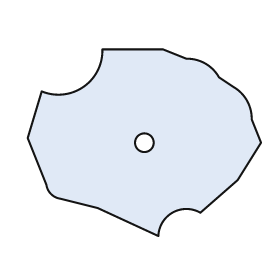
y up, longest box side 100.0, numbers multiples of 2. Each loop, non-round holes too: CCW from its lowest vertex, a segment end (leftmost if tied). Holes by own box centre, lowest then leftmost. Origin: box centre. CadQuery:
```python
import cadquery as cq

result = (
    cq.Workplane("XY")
    .moveTo(6.0, -40.0)
    .threePointArc((12.0, -30.0), (24.0, -30.0))
    .lineTo(40.0, -16.0)
    .lineTo(50.0, 0.0)
    .lineTo(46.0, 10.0)
    .threePointArc((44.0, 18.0), (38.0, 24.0))
    .lineTo(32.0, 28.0)
    .threePointArc((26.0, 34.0), (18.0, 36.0))
    .lineTo(8.0, 40.0)
    .lineTo(-18.0, 40.0)
    .threePointArc((-26.0, 24.0), (-44.0, 22.0))
    .lineTo(-50.0, 2.0)
    .lineTo(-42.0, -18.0)
    .threePointArc((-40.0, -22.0), (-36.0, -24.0))
    .lineTo(-20.0, -28.0)
    .close()
    .moveTo(0.0, 0.0)
    .circle(4.0)
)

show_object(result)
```